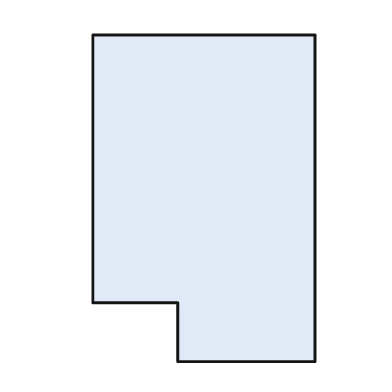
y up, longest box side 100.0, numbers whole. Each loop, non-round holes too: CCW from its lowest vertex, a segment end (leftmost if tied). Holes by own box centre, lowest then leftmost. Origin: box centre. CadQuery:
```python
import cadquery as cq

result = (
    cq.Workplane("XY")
    .moveTo(-8.0, -50.0)
    .lineTo(34.0, -50.0)
    .lineTo(34.0, 50.0)
    .lineTo(-34.0, 50.0)
    .lineTo(-34.0, -32.0)
    .lineTo(-8.0, -32.0)
    .close()
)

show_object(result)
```